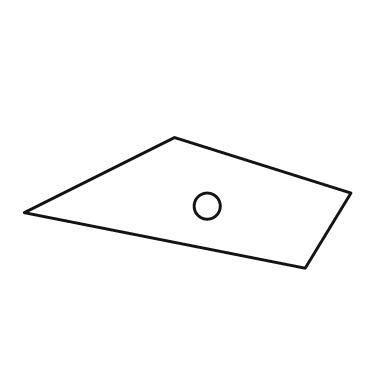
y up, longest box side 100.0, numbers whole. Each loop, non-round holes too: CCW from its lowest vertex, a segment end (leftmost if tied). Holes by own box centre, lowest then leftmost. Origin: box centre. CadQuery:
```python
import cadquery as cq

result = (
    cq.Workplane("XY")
    .moveTo(36.0, -20.0)
    .lineTo(50.0, 3.0)
    .lineTo(-4.0, 20.0)
    .lineTo(-50.0, -3.0)
    .close()
    .moveTo(6.0, -1.0)
    .circle(4.0)
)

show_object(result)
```